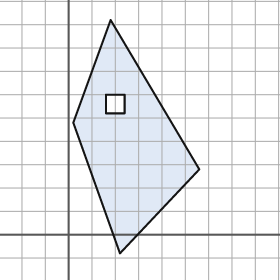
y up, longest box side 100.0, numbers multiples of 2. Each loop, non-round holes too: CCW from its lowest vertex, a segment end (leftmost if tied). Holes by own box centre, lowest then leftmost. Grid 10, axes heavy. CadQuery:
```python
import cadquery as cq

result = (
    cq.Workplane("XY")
    .moveTo(22.0, -8.0)
    .lineTo(56.0, 28.0)
    .lineTo(18.0, 92.0)
    .lineTo(2.0, 48.0)
    .close()
    .moveTo(16.0, 52.0)
    .lineTo(24.0, 52.0)
    .lineTo(24.0, 60.0)
    .lineTo(16.0, 60.0)
    .close()
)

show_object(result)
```